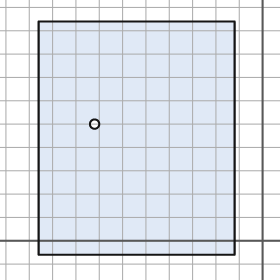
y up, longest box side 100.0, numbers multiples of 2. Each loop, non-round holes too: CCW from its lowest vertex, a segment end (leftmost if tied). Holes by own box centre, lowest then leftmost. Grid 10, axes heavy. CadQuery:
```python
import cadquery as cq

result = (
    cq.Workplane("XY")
    .moveTo(-96.0, -6.0)
    .lineTo(-12.0, -6.0)
    .lineTo(-12.0, 94.0)
    .lineTo(-96.0, 94.0)
    .close()
    .moveTo(-72.0, 50.0)
    .circle(2.0)
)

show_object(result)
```